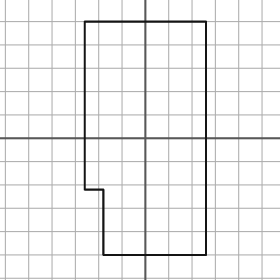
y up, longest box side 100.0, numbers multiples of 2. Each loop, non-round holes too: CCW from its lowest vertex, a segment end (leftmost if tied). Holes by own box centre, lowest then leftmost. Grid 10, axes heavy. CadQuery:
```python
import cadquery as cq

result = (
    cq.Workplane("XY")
    .moveTo(-18.0, -50.0)
    .lineTo(26.0, -50.0)
    .lineTo(26.0, 50.0)
    .lineTo(-26.0, 50.0)
    .lineTo(-26.0, -22.0)
    .lineTo(-18.0, -22.0)
    .close()
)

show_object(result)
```